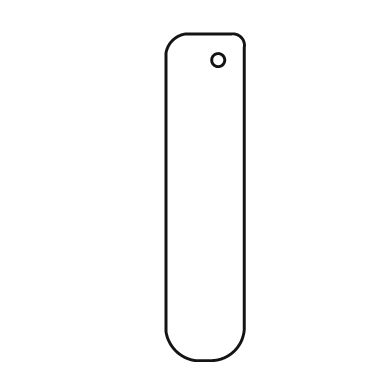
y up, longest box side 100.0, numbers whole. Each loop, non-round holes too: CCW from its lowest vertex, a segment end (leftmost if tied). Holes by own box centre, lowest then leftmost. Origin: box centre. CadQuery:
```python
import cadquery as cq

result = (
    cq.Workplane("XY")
    .moveTo(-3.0, -50.0)
    .lineTo(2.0, -50.0)
    .threePointArc((9.0, -47.0), (12.0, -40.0))
    .lineTo(12.0, 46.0)
    .threePointArc((11.0, 49.0), (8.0, 50.0))
    .lineTo(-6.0, 50.0)
    .threePointArc((-10.0, 48.0), (-12.0, 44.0))
    .lineTo(-12.0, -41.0)
    .threePointArc((-9.0, -47.0), (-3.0, -50.0))
    .close()
    .moveTo(4.0, 42.0)
    .circle(2.0)
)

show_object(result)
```